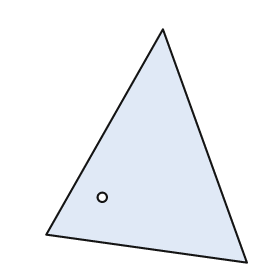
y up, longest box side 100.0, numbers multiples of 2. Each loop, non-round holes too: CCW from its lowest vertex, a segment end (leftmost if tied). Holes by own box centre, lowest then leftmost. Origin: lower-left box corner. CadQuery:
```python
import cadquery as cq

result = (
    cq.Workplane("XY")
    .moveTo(86.0, 0.0)
    .lineTo(50.0, 100.0)
    .lineTo(0.0, 12.0)
    .close()
    .moveTo(24.0, 28.0)
    .circle(2.0)
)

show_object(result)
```